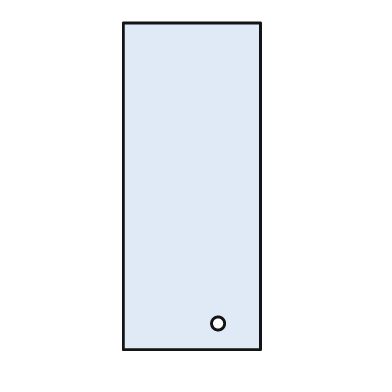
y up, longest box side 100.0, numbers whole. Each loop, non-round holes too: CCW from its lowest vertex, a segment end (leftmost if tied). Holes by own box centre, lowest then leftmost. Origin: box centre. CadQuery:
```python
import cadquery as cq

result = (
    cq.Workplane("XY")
    .moveTo(-21.0, -50.0)
    .lineTo(21.0, -50.0)
    .lineTo(21.0, 50.0)
    .lineTo(-21.0, 50.0)
    .close()
    .moveTo(8.0, -42.0)
    .circle(2.0)
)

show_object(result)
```